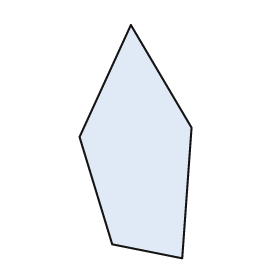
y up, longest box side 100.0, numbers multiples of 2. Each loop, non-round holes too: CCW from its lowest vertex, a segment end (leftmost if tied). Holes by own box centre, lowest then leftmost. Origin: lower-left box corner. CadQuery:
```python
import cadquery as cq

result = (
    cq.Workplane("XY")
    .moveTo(44.0, 0.0)
    .lineTo(48.0, 56.0)
    .lineTo(22.0, 100.0)
    .lineTo(0.0, 52.0)
    .lineTo(14.0, 6.0)
    .close()
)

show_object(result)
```